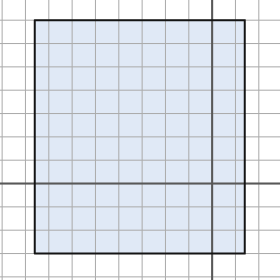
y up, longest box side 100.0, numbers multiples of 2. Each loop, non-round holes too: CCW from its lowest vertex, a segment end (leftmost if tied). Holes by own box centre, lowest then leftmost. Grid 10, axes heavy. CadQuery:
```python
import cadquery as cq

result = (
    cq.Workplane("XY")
    .moveTo(-76.0, -30.0)
    .lineTo(14.0, -30.0)
    .lineTo(14.0, 70.0)
    .lineTo(-76.0, 70.0)
    .close()
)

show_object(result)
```